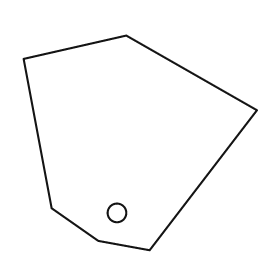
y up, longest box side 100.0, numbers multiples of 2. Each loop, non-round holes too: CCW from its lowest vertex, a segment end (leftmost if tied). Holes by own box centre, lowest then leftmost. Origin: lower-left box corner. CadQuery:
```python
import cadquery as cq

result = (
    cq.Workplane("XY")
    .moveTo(54.0, 0.0)
    .lineTo(100.0, 60.0)
    .lineTo(44.0, 92.0)
    .lineTo(0.0, 82.0)
    .lineTo(12.0, 18.0)
    .lineTo(32.0, 4.0)
    .close()
    .moveTo(40.0, 16.0)
    .circle(4.0)
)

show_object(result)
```